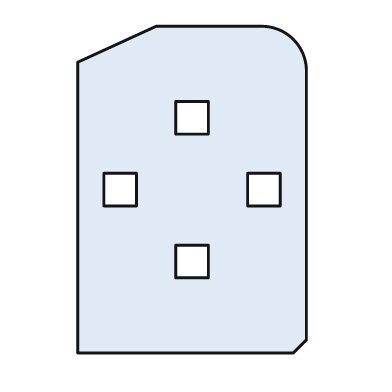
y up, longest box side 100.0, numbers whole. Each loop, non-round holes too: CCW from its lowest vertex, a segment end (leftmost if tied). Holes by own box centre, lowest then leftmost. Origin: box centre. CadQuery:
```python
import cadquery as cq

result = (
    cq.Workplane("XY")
    .moveTo(-35.0, -50.0)
    .lineTo(31.0, -50.0)
    .lineTo(35.0, -46.0)
    .lineTo(35.0, 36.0)
    .threePointArc((31.0, 46.0), (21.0, 50.0))
    .lineTo(-11.0, 50.0)
    .lineTo(-35.0, 39.0)
    .close()
    .moveTo(-5.0, -27.0)
    .lineTo(5.0, -27.0)
    .lineTo(5.0, -17.0)
    .lineTo(-5.0, -17.0)
    .close()
    .moveTo(-27.0, -5.0)
    .lineTo(-17.0, -5.0)
    .lineTo(-17.0, 5.0)
    .lineTo(-27.0, 5.0)
    .close()
    .moveTo(17.0, -5.0)
    .lineTo(27.0, -5.0)
    .lineTo(27.0, 5.0)
    .lineTo(17.0, 5.0)
    .close()
    .moveTo(-5.0, 17.0)
    .lineTo(5.0, 17.0)
    .lineTo(5.0, 27.0)
    .lineTo(-5.0, 27.0)
    .close()
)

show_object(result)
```